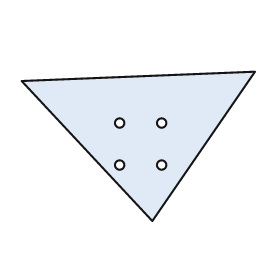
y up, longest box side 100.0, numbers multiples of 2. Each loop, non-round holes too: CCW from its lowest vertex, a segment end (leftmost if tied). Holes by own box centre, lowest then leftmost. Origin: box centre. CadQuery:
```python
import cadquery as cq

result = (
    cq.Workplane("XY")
    .moveTo(6.0, -32.0)
    .lineTo(50.0, 32.0)
    .lineTo(-50.0, 28.0)
    .close()
    .moveTo(-8.0, -8.0)
    .circle(2.0)
    .moveTo(10.0, -8.0)
    .circle(2.0)
    .moveTo(-8.0, 10.0)
    .circle(2.0)
    .moveTo(10.0, 10.0)
    .circle(2.0)
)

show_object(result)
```